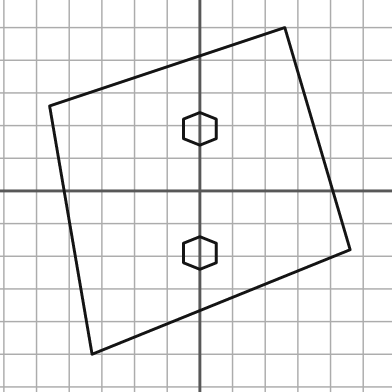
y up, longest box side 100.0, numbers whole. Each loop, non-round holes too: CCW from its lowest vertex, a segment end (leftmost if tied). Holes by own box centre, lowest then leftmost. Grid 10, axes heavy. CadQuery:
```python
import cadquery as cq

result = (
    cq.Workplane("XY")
    .moveTo(-33.0, -50.0)
    .lineTo(46.0, -18.0)
    .lineTo(26.0, 50.0)
    .lineTo(-46.0, 26.0)
    .close()
    .moveTo(0.0, -24.0)
    .lineTo(5.0, -22.0)
    .lineTo(5.0, -16.0)
    .lineTo(0.0, -14.0)
    .lineTo(-5.0, -16.0)
    .lineTo(-5.0, -22.0)
    .close()
    .moveTo(0.0, 14.0)
    .lineTo(5.0, 16.0)
    .lineTo(5.0, 22.0)
    .lineTo(0.0, 24.0)
    .lineTo(-5.0, 22.0)
    .lineTo(-5.0, 16.0)
    .close()
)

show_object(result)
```